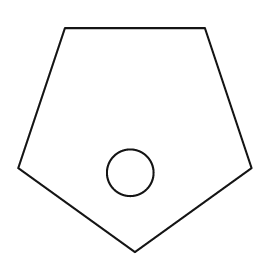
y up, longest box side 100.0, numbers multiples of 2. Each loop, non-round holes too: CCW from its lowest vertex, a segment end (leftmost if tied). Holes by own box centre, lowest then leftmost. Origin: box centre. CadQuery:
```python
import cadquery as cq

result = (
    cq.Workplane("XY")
    .moveTo(0.0, -48.0)
    .lineTo(50.0, -12.0)
    .lineTo(30.0, 48.0)
    .lineTo(-30.0, 48.0)
    .lineTo(-50.0, -12.0)
    .close()
    .moveTo(-2.0, -14.0)
    .circle(10.0)
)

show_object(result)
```